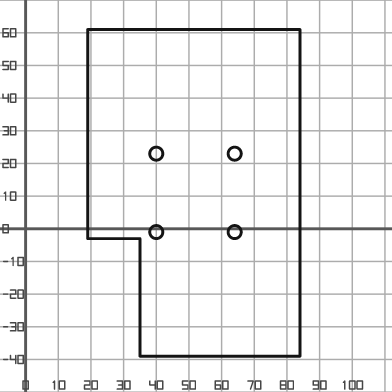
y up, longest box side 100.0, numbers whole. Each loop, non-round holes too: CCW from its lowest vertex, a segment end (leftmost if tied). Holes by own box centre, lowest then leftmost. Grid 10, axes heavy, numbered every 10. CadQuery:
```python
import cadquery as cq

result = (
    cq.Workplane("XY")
    .moveTo(35.0, -39.0)
    .lineTo(84.0, -39.0)
    .lineTo(84.0, 61.0)
    .lineTo(19.0, 61.0)
    .lineTo(19.0, -3.0)
    .lineTo(35.0, -3.0)
    .close()
    .moveTo(40.0, -1.0)
    .circle(2.0)
    .moveTo(64.0, -1.0)
    .circle(2.0)
    .moveTo(40.0, 23.0)
    .circle(2.0)
    .moveTo(64.0, 23.0)
    .circle(2.0)
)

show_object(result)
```